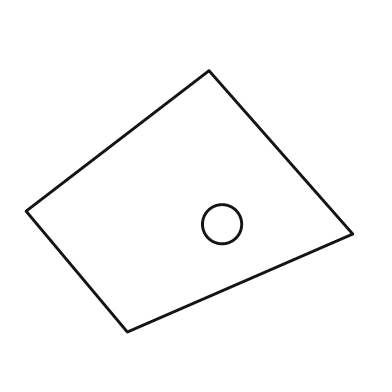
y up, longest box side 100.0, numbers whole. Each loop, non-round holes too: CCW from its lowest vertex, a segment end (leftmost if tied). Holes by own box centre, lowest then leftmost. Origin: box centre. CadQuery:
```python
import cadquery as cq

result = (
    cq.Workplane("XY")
    .moveTo(-19.0, -40.0)
    .lineTo(50.0, -10.0)
    .lineTo(6.0, 40.0)
    .lineTo(-50.0, -3.0)
    .close()
    .moveTo(10.0, -7.0)
    .circle(6.0)
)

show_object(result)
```